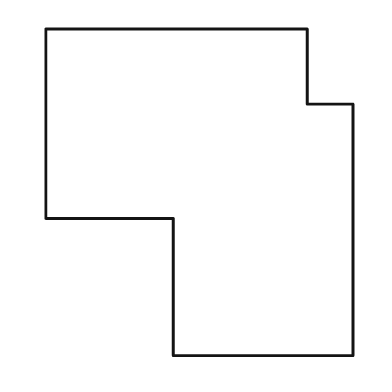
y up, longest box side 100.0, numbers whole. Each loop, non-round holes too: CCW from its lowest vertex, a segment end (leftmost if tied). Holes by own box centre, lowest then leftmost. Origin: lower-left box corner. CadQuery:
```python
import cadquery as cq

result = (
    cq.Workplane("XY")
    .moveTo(39.0, 0.0)
    .lineTo(94.0, 0.0)
    .lineTo(94.0, 77.0)
    .lineTo(80.0, 77.0)
    .lineTo(80.0, 100.0)
    .lineTo(0.0, 100.0)
    .lineTo(0.0, 42.0)
    .lineTo(39.0, 42.0)
    .close()
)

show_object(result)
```